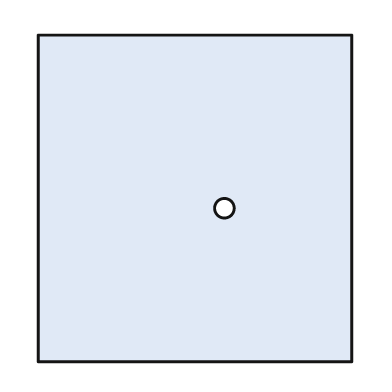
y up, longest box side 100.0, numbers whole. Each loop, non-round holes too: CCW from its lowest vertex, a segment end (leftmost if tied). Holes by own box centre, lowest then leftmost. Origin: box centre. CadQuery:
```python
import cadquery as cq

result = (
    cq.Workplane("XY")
    .moveTo(-48.0, -50.0)
    .lineTo(48.0, -50.0)
    .lineTo(48.0, 50.0)
    .lineTo(-48.0, 50.0)
    .close()
    .moveTo(9.0, -3.0)
    .circle(3.0)
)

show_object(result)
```